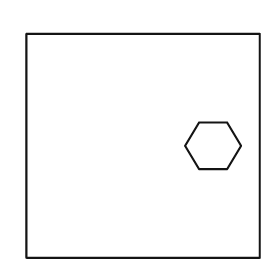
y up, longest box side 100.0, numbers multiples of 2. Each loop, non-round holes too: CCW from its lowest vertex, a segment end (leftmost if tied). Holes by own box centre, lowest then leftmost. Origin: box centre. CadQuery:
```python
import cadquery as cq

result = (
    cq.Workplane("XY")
    .moveTo(-50.0, -48.0)
    .lineTo(50.0, -48.0)
    .lineTo(50.0, 48.0)
    .lineTo(-50.0, 48.0)
    .close()
    .moveTo(24.0, -10.0)
    .lineTo(36.0, -10.0)
    .lineTo(42.0, 0.0)
    .lineTo(36.0, 10.0)
    .lineTo(24.0, 10.0)
    .lineTo(18.0, 0.0)
    .close()
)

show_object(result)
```